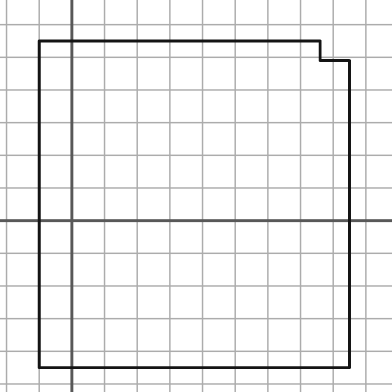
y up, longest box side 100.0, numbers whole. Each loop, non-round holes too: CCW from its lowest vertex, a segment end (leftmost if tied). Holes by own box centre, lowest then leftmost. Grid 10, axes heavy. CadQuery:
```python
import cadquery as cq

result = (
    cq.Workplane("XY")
    .moveTo(-10.0, -45.0)
    .lineTo(85.0, -45.0)
    .lineTo(85.0, 49.0)
    .lineTo(76.0, 49.0)
    .lineTo(76.0, 55.0)
    .lineTo(-10.0, 55.0)
    .close()
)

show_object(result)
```